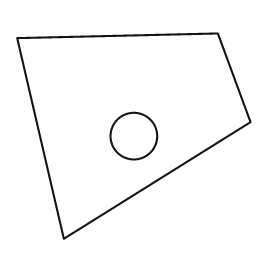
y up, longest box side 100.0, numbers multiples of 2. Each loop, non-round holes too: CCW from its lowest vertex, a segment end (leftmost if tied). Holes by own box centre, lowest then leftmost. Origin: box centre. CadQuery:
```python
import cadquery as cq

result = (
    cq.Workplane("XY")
    .moveTo(-30.0, -44.0)
    .lineTo(50.0, 6.0)
    .lineTo(36.0, 44.0)
    .lineTo(-50.0, 42.0)
    .close()
    .moveTo(0.0, 0.0)
    .circle(10.0)
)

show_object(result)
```